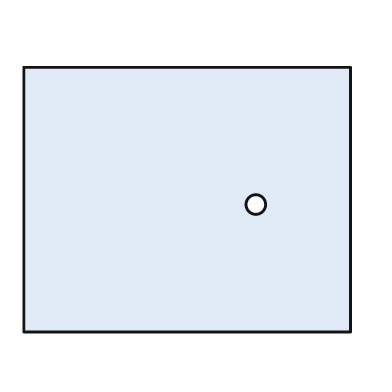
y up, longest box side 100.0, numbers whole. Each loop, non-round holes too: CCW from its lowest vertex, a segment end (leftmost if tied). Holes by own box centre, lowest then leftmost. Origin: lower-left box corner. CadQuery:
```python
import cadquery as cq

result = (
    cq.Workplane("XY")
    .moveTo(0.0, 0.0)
    .lineTo(100.0, 0.0)
    .lineTo(100.0, 81.0)
    .lineTo(0.0, 81.0)
    .close()
    .moveTo(71.0, 39.0)
    .circle(3.0)
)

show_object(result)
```